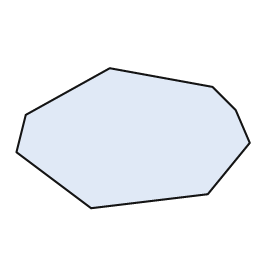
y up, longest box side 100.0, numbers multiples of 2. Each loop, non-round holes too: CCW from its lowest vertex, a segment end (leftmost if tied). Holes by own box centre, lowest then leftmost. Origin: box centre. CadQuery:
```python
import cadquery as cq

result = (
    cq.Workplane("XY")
    .moveTo(-18.0, -30.0)
    .lineTo(32.0, -24.0)
    .lineTo(50.0, -2.0)
    .lineTo(44.0, 12.0)
    .lineTo(34.0, 22.0)
    .lineTo(-10.0, 30.0)
    .lineTo(-46.0, 10.0)
    .lineTo(-50.0, -6.0)
    .close()
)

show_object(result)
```